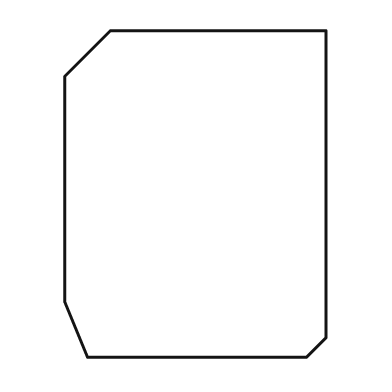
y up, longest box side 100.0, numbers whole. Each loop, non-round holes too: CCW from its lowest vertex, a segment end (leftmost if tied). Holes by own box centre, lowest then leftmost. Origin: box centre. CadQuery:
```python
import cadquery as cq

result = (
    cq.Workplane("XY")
    .moveTo(-33.0, -50.0)
    .lineTo(34.0, -50.0)
    .lineTo(40.0, -44.0)
    .lineTo(40.0, 50.0)
    .lineTo(-26.0, 50.0)
    .lineTo(-40.0, 36.0)
    .lineTo(-40.0, -33.0)
    .close()
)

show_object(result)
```